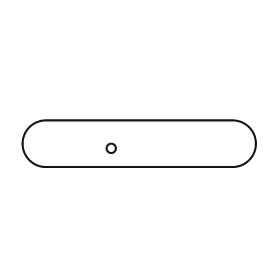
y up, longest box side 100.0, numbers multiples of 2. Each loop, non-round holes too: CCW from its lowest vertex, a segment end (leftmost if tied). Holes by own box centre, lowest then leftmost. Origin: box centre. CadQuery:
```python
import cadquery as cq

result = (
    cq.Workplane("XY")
    .moveTo(-40.0, -10.0)
    .lineTo(40.0, -10.0)
    .threePointArc((50.0, 0.0), (40.0, 10.0))
    .lineTo(-40.0, 10.0)
    .threePointArc((-50.0, 0.0), (-40.0, -10.0))
    .close()
    .moveTo(-12.0, -2.0)
    .circle(2.0)
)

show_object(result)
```